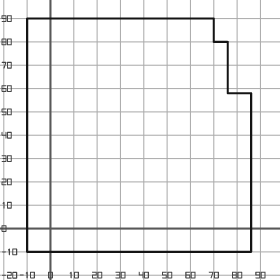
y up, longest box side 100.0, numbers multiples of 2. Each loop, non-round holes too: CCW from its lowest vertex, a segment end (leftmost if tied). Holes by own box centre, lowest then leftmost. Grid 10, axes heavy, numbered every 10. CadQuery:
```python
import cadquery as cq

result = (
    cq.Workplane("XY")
    .moveTo(-10.0, -10.0)
    .lineTo(86.0, -10.0)
    .lineTo(86.0, 58.0)
    .lineTo(76.0, 58.0)
    .lineTo(76.0, 80.0)
    .lineTo(70.0, 80.0)
    .lineTo(70.0, 90.0)
    .lineTo(-10.0, 90.0)
    .close()
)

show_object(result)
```